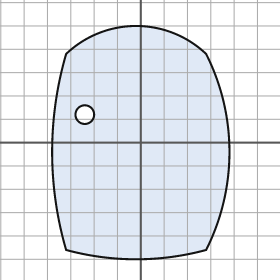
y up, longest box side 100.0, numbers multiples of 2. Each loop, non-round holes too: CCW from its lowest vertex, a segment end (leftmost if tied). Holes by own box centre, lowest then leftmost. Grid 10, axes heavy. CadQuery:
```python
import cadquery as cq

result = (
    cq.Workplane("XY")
    .moveTo(-32.0, -46.0)
    .threePointArc((-2.0, -50.0), (28.0, -46.0))
    .threePointArc((38.0, -4.0), (28.0, 38.0))
    .threePointArc((-2.0, 50.0), (-32.0, 38.0))
    .threePointArc((-38.0, -4.0), (-32.0, -46.0))
    .close()
    .moveTo(-24.0, 12.0)
    .circle(4.0)
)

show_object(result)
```